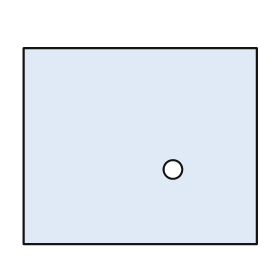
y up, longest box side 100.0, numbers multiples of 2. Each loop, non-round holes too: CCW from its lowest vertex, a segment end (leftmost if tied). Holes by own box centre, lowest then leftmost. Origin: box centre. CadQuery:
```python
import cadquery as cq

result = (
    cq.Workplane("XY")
    .moveTo(-50.0, -42.0)
    .lineTo(50.0, -42.0)
    .lineTo(50.0, 42.0)
    .lineTo(-50.0, 42.0)
    .close()
    .moveTo(14.0, -10.0)
    .circle(4.0)
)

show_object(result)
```